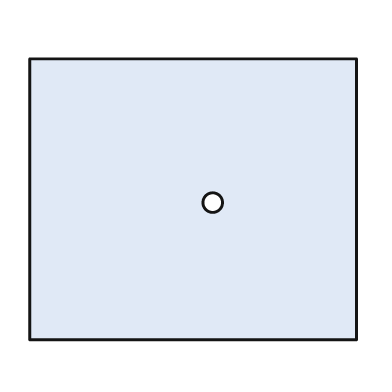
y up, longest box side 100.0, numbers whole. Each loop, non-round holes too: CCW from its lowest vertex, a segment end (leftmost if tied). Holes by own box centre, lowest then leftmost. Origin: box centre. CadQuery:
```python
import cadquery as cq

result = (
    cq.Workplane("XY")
    .moveTo(-50.0, -43.0)
    .lineTo(50.0, -43.0)
    .lineTo(50.0, 43.0)
    .lineTo(-50.0, 43.0)
    .close()
    .moveTo(6.0, -1.0)
    .circle(3.0)
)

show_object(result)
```